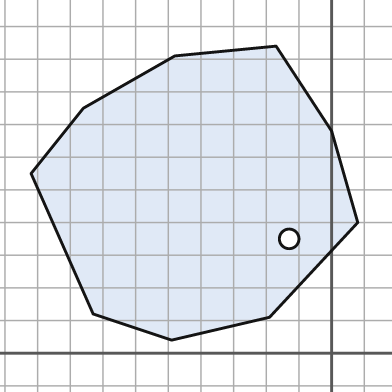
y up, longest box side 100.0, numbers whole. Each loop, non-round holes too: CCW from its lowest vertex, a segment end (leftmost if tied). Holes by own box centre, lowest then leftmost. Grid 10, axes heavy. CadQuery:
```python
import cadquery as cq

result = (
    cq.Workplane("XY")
    .moveTo(-49.0, 4.0)
    .lineTo(-19.0, 11.0)
    .lineTo(8.0, 40.0)
    .lineTo(0.0, 68.0)
    .lineTo(-17.0, 94.0)
    .lineTo(-48.0, 91.0)
    .lineTo(-76.0, 75.0)
    .lineTo(-92.0, 55.0)
    .lineTo(-73.0, 12.0)
    .close()
    .moveTo(-13.0, 35.0)
    .circle(3.0)
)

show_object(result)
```